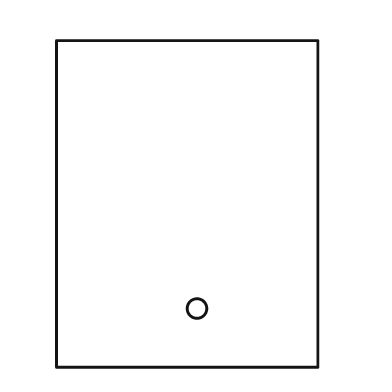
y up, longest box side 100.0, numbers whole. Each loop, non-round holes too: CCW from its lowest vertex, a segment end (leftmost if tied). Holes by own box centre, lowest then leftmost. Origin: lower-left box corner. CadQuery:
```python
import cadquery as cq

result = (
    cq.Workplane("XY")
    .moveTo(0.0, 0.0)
    .lineTo(80.0, 0.0)
    .lineTo(80.0, 100.0)
    .lineTo(0.0, 100.0)
    .close()
    .moveTo(43.0, 18.0)
    .circle(3.0)
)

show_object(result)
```